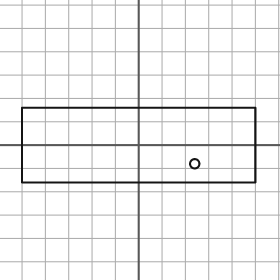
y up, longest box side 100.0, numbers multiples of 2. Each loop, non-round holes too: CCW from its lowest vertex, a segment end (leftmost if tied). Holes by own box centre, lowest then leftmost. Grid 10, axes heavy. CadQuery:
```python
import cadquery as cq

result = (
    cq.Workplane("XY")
    .moveTo(-50.0, -16.0)
    .lineTo(50.0, -16.0)
    .lineTo(50.0, 16.0)
    .lineTo(-50.0, 16.0)
    .close()
    .moveTo(24.0, -8.0)
    .circle(2.0)
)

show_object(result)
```